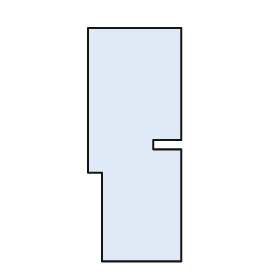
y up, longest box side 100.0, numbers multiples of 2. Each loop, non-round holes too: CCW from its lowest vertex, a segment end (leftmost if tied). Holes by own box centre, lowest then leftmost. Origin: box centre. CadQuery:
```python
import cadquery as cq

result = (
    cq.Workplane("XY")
    .moveTo(-14.0, -50.0)
    .lineTo(20.0, -50.0)
    .lineTo(20.0, -2.0)
    .lineTo(8.0, -2.0)
    .lineTo(8.0, 2.0)
    .lineTo(20.0, 2.0)
    .lineTo(20.0, 50.0)
    .lineTo(-20.0, 50.0)
    .lineTo(-20.0, -12.0)
    .lineTo(-14.0, -12.0)
    .close()
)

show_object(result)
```